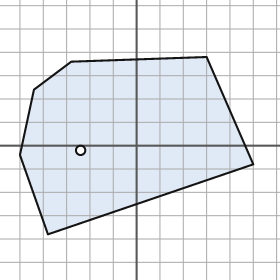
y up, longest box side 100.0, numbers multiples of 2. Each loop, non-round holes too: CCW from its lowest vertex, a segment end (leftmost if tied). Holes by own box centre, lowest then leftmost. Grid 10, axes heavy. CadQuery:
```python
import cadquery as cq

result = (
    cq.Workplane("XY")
    .moveTo(-38.0, -38.0)
    .lineTo(50.0, -8.0)
    .lineTo(30.0, 38.0)
    .lineTo(-28.0, 36.0)
    .lineTo(-44.0, 24.0)
    .lineTo(-50.0, -4.0)
    .close()
    .moveTo(-24.0, -2.0)
    .circle(2.0)
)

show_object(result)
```